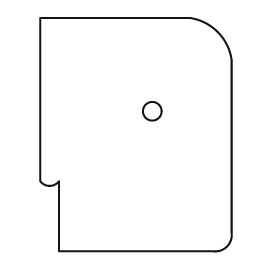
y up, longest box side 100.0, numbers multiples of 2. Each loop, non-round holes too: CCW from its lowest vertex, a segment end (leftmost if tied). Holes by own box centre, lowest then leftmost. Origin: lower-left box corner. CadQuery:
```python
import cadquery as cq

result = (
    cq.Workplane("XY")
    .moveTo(8.0, 0.0)
    .lineTo(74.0, 0.0)
    .threePointArc((80.0, 2.0), (82.0, 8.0))
    .lineTo(82.0, 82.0)
    .threePointArc((76.0, 94.0), (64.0, 100.0))
    .lineTo(0.0, 100.0)
    .lineTo(0.0, 30.0)
    .threePointArc((4.0, 28.0), (8.0, 30.0))
    .close()
    .moveTo(48.0, 60.0)
    .circle(4.0)
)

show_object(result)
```